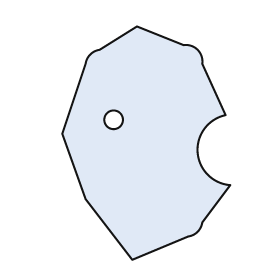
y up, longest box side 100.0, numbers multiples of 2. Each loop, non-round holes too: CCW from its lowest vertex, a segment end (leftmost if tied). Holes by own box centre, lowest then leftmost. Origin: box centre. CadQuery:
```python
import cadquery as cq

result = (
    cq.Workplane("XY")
    .moveTo(-6.0, -50.0)
    .lineTo(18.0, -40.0)
    .threePointArc((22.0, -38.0), (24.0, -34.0))
    .lineTo(36.0, -18.0)
    .threePointArc((22.0, -4.0), (34.0, 12.0))
    .lineTo(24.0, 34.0)
    .threePointArc((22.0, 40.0), (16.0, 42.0))
    .lineTo(-4.0, 50.0)
    .lineTo(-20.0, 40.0)
    .threePointArc((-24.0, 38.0), (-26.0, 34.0))
    .lineTo(-36.0, 4.0)
    .lineTo(-26.0, -24.0)
    .close()
    .moveTo(-14.0, 10.0)
    .circle(4.0)
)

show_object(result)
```